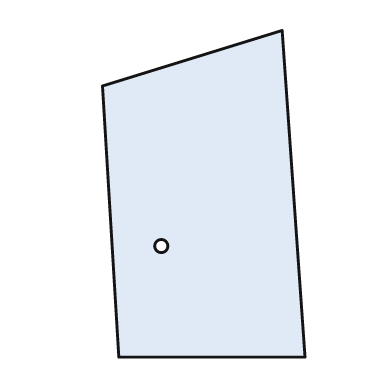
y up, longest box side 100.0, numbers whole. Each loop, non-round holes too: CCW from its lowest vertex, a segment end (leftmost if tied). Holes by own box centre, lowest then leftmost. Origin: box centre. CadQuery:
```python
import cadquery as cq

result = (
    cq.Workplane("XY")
    .moveTo(-26.0, -50.0)
    .lineTo(31.0, -50.0)
    .lineTo(24.0, 50.0)
    .lineTo(-31.0, 33.0)
    .close()
    .moveTo(-13.0, -16.0)
    .circle(2.0)
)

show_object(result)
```